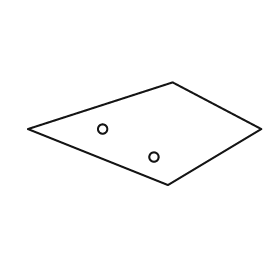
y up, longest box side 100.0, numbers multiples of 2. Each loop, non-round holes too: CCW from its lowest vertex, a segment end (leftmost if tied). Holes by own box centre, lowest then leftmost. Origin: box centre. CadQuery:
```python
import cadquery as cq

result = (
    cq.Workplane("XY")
    .moveTo(10.0, -22.0)
    .lineTo(50.0, 2.0)
    .lineTo(12.0, 22.0)
    .lineTo(-50.0, 2.0)
    .close()
    .moveTo(4.0, -10.0)
    .circle(2.0)
    .moveTo(-18.0, 2.0)
    .circle(2.0)
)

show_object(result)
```